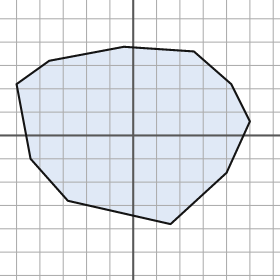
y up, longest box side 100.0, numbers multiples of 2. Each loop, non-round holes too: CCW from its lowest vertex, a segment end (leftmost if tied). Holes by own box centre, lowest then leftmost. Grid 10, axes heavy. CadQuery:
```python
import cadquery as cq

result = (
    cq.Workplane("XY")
    .moveTo(16.0, -38.0)
    .lineTo(40.0, -16.0)
    .lineTo(50.0, 6.0)
    .lineTo(42.0, 22.0)
    .lineTo(26.0, 36.0)
    .lineTo(-4.0, 38.0)
    .lineTo(-36.0, 32.0)
    .lineTo(-50.0, 22.0)
    .lineTo(-44.0, -10.0)
    .lineTo(-28.0, -28.0)
    .close()
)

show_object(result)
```